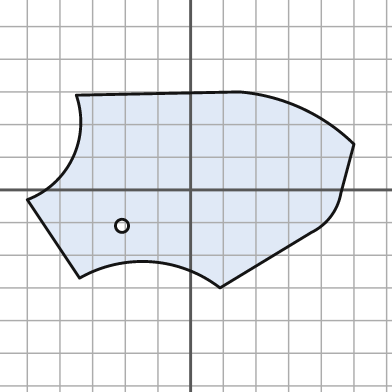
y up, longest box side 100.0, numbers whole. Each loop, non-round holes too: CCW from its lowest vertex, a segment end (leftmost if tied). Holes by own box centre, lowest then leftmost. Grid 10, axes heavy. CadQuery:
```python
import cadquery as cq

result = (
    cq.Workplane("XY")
    .moveTo(9.0, -30.0)
    .lineTo(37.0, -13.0)
    .threePointArc((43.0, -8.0), (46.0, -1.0))
    .lineTo(50.0, 14.0)
    .threePointArc((34.0, 25.0), (15.0, 30.0))
    .lineTo(-35.0, 29.0)
    .threePointArc((-36.0, 10.0), (-50.0, -3.0))
    .lineTo(-34.0, -27.0)
    .threePointArc((-12.0, -22.0), (9.0, -30.0))
    .close()
    .moveTo(-21.0, -11.0)
    .circle(2.0)
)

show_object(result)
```